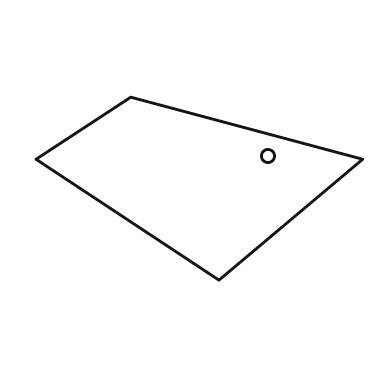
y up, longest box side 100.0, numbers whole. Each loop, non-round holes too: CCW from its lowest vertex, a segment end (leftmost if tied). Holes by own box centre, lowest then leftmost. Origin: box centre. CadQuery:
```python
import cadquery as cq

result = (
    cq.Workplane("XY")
    .moveTo(6.0, -28.0)
    .lineTo(50.0, 9.0)
    .lineTo(-21.0, 28.0)
    .lineTo(-50.0, 9.0)
    .close()
    .moveTo(21.0, 10.0)
    .circle(2.0)
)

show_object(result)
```